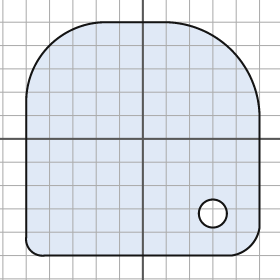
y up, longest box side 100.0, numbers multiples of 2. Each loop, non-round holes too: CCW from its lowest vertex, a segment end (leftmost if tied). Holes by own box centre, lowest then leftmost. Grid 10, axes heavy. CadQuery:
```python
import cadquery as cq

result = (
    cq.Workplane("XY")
    .moveTo(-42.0, -50.0)
    .lineTo(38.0, -50.0)
    .threePointArc((46.0, -46.0), (50.0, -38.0))
    .lineTo(50.0, 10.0)
    .threePointArc((38.0, 38.0), (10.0, 50.0))
    .lineTo(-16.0, 50.0)
    .threePointArc((-40.0, 40.0), (-50.0, 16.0))
    .lineTo(-50.0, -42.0)
    .threePointArc((-48.0, -48.0), (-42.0, -50.0))
    .close()
    .moveTo(30.0, -32.0)
    .circle(6.0)
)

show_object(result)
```